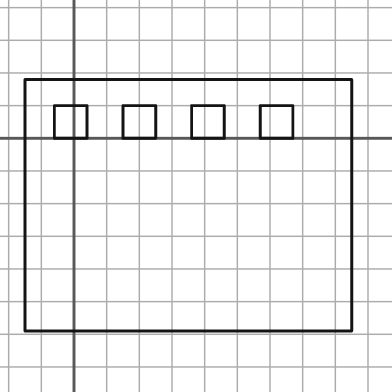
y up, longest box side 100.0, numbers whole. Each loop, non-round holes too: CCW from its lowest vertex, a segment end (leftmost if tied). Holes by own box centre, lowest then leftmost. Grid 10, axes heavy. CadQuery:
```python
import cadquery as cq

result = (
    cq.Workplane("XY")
    .moveTo(-15.0, -59.0)
    .lineTo(85.0, -59.0)
    .lineTo(85.0, 18.0)
    .lineTo(-15.0, 18.0)
    .close()
    .moveTo(-6.0, 0.0)
    .lineTo(4.0, 0.0)
    .lineTo(4.0, 10.0)
    .lineTo(-6.0, 10.0)
    .close()
    .moveTo(15.0, 0.0)
    .lineTo(25.0, 0.0)
    .lineTo(25.0, 10.0)
    .lineTo(15.0, 10.0)
    .close()
    .moveTo(36.0, 0.0)
    .lineTo(46.0, 0.0)
    .lineTo(46.0, 10.0)
    .lineTo(36.0, 10.0)
    .close()
    .moveTo(57.0, 0.0)
    .lineTo(67.0, 0.0)
    .lineTo(67.0, 10.0)
    .lineTo(57.0, 10.0)
    .close()
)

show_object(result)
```